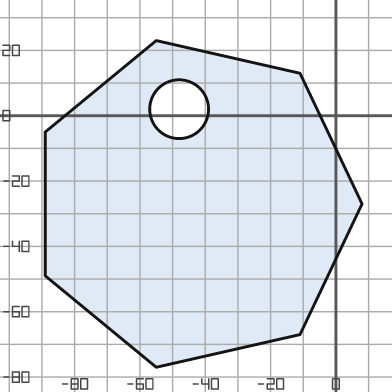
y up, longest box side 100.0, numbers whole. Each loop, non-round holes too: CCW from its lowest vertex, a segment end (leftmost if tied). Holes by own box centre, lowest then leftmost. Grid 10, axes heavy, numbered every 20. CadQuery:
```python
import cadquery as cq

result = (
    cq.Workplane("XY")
    .moveTo(-55.0, -77.0)
    .lineTo(-11.0, -67.0)
    .lineTo(8.0, -27.0)
    .lineTo(-11.0, 13.0)
    .lineTo(-55.0, 23.0)
    .lineTo(-89.0, -5.0)
    .lineTo(-89.0, -49.0)
    .close()
    .moveTo(-48.0, 2.0)
    .circle(9.0)
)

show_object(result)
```